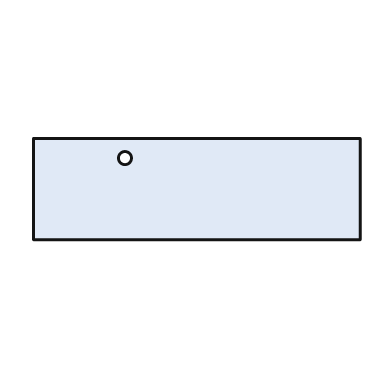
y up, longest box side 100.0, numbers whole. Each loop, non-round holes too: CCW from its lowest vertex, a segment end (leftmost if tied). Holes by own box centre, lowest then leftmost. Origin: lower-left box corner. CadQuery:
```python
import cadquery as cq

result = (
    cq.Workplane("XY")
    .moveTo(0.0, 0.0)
    .lineTo(100.0, 0.0)
    .lineTo(100.0, 31.0)
    .lineTo(0.0, 31.0)
    .close()
    .moveTo(28.0, 25.0)
    .circle(2.0)
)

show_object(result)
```